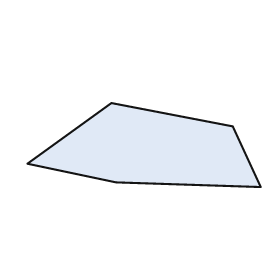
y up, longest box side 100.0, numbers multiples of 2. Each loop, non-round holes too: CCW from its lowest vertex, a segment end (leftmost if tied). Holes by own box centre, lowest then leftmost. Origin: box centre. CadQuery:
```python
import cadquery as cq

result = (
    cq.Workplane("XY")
    .moveTo(50.0, -18.0)
    .lineTo(38.0, 8.0)
    .lineTo(-14.0, 18.0)
    .lineTo(-50.0, -8.0)
    .lineTo(-12.0, -16.0)
    .close()
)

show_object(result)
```